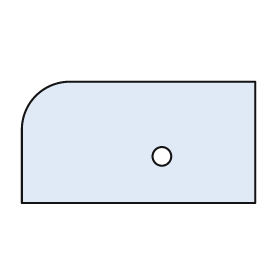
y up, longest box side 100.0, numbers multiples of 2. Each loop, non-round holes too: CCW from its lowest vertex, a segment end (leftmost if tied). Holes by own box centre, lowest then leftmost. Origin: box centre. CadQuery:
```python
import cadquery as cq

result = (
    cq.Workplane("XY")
    .moveTo(-50.0, -26.0)
    .lineTo(50.0, -26.0)
    .lineTo(50.0, 26.0)
    .lineTo(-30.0, 26.0)
    .threePointArc((-44.0, 20.0), (-50.0, 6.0))
    .close()
    .moveTo(10.0, -6.0)
    .circle(4.0)
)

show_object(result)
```